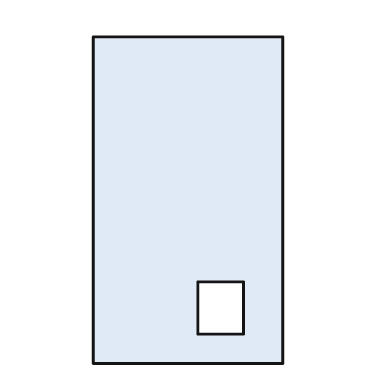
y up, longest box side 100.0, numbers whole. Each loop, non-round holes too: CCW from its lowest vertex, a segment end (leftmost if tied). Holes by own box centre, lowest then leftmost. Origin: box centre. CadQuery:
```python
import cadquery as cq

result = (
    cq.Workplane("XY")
    .moveTo(-29.0, -50.0)
    .lineTo(29.0, -50.0)
    .lineTo(29.0, 50.0)
    .lineTo(-29.0, 50.0)
    .close()
    .moveTo(3.0, -41.0)
    .lineTo(17.0, -41.0)
    .lineTo(17.0, -25.0)
    .lineTo(3.0, -25.0)
    .close()
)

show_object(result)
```